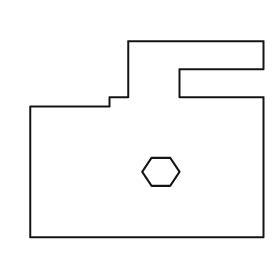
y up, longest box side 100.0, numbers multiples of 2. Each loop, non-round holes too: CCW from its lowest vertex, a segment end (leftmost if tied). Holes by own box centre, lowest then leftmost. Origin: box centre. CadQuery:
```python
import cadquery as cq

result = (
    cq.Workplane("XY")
    .moveTo(-50.0, -42.0)
    .lineTo(50.0, -42.0)
    .lineTo(50.0, 18.0)
    .lineTo(14.0, 18.0)
    .lineTo(14.0, 30.0)
    .lineTo(50.0, 30.0)
    .lineTo(50.0, 42.0)
    .lineTo(-8.0, 42.0)
    .lineTo(-8.0, 18.0)
    .lineTo(-16.0, 18.0)
    .lineTo(-16.0, 14.0)
    .lineTo(-50.0, 14.0)
    .close()
    .moveTo(2.0, -20.0)
    .lineTo(10.0, -20.0)
    .lineTo(14.0, -14.0)
    .lineTo(10.0, -8.0)
    .lineTo(2.0, -8.0)
    .lineTo(-2.0, -14.0)
    .close()
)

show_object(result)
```